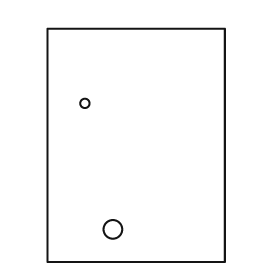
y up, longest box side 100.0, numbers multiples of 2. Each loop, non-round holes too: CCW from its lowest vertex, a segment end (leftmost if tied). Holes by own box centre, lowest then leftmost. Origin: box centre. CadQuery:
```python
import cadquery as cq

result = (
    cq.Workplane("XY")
    .moveTo(-38.0, -50.0)
    .lineTo(38.0, -50.0)
    .lineTo(38.0, 50.0)
    .lineTo(-38.0, 50.0)
    .close()
    .moveTo(-10.0, -36.0)
    .circle(4.0)
    .moveTo(-22.0, 18.0)
    .circle(2.0)
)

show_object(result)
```